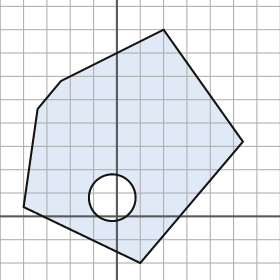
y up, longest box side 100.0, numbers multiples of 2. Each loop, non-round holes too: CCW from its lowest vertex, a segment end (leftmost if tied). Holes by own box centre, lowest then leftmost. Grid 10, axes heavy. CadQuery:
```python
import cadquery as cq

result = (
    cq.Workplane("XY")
    .moveTo(10.0, -20.0)
    .lineTo(54.0, 32.0)
    .lineTo(20.0, 80.0)
    .lineTo(-24.0, 58.0)
    .lineTo(-34.0, 46.0)
    .lineTo(-40.0, 4.0)
    .close()
    .moveTo(-2.0, 8.0)
    .circle(10.0)
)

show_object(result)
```